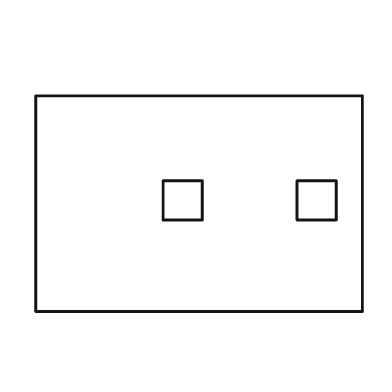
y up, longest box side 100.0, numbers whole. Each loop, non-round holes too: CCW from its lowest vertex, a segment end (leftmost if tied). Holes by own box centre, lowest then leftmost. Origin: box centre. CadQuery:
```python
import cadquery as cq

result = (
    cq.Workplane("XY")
    .moveTo(-50.0, -33.0)
    .lineTo(50.0, -33.0)
    .lineTo(50.0, 33.0)
    .lineTo(-50.0, 33.0)
    .close()
    .moveTo(-11.0, -5.0)
    .lineTo(1.0, -5.0)
    .lineTo(1.0, 7.0)
    .lineTo(-11.0, 7.0)
    .close()
    .moveTo(30.0, -5.0)
    .lineTo(42.0, -5.0)
    .lineTo(42.0, 7.0)
    .lineTo(30.0, 7.0)
    .close()
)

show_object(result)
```